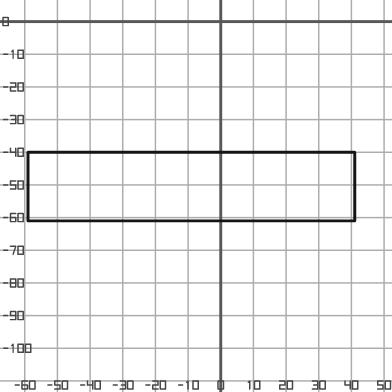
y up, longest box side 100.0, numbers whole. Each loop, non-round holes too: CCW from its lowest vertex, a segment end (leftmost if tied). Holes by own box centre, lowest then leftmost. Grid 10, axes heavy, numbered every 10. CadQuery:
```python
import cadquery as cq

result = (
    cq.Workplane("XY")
    .moveTo(-59.0, -61.0)
    .lineTo(41.0, -61.0)
    .lineTo(41.0, -40.0)
    .lineTo(-59.0, -40.0)
    .close()
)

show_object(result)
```